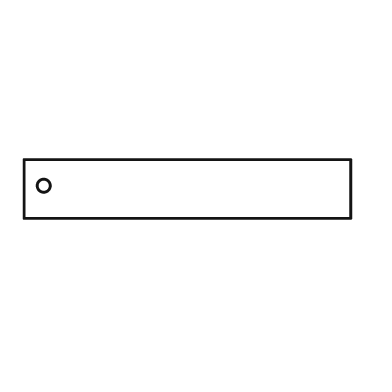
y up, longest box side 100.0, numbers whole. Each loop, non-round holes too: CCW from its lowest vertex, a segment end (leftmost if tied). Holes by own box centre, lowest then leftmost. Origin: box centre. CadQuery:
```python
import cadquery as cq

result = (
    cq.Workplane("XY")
    .moveTo(-50.0, -9.0)
    .lineTo(50.0, -9.0)
    .lineTo(50.0, 9.0)
    .lineTo(-50.0, 9.0)
    .close()
    .moveTo(-44.0, 1.0)
    .circle(2.0)
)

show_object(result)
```